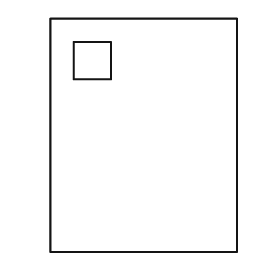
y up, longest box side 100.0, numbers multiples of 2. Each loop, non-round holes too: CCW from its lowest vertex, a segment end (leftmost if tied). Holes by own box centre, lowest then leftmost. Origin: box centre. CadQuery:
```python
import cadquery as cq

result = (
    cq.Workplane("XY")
    .moveTo(-40.0, -50.0)
    .lineTo(40.0, -50.0)
    .lineTo(40.0, 50.0)
    .lineTo(-40.0, 50.0)
    .close()
    .moveTo(-30.0, 24.0)
    .lineTo(-14.0, 24.0)
    .lineTo(-14.0, 40.0)
    .lineTo(-30.0, 40.0)
    .close()
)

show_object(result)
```